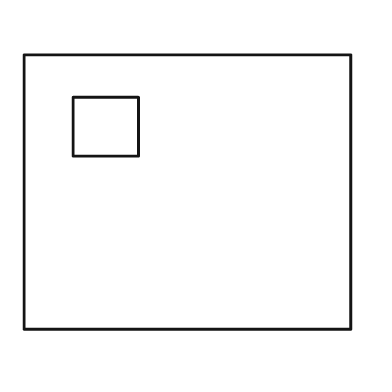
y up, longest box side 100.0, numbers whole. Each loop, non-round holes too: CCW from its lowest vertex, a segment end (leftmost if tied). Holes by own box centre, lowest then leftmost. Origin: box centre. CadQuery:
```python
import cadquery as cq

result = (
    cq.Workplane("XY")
    .moveTo(-50.0, -42.0)
    .lineTo(50.0, -42.0)
    .lineTo(50.0, 42.0)
    .lineTo(-50.0, 42.0)
    .close()
    .moveTo(-35.0, 11.0)
    .lineTo(-15.0, 11.0)
    .lineTo(-15.0, 29.0)
    .lineTo(-35.0, 29.0)
    .close()
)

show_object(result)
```